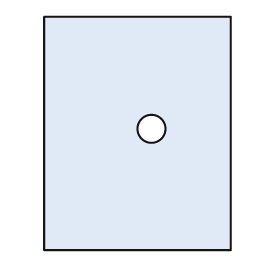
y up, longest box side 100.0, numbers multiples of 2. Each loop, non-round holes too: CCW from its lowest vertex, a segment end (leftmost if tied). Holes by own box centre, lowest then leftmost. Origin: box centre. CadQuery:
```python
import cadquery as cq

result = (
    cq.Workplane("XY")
    .moveTo(-40.0, -50.0)
    .lineTo(40.0, -50.0)
    .lineTo(40.0, 50.0)
    .lineTo(-40.0, 50.0)
    .close()
    .moveTo(6.0, 2.0)
    .circle(6.0)
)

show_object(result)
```